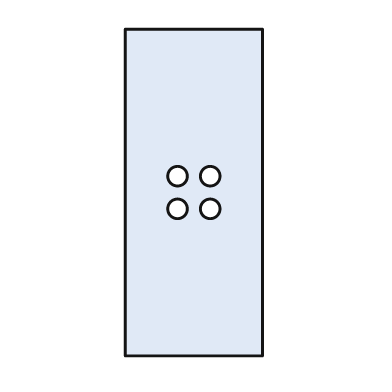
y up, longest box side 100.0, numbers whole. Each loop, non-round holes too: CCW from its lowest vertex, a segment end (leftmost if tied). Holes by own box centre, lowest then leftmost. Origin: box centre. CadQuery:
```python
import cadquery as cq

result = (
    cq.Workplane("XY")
    .moveTo(-21.0, -50.0)
    .lineTo(21.0, -50.0)
    .lineTo(21.0, 50.0)
    .lineTo(-21.0, 50.0)
    .close()
    .moveTo(-5.0, -5.0)
    .circle(3.0)
    .moveTo(5.0, -5.0)
    .circle(3.0)
    .moveTo(-5.0, 5.0)
    .circle(3.0)
    .moveTo(5.0, 5.0)
    .circle(3.0)
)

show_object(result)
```